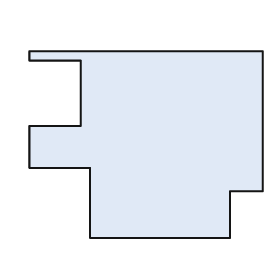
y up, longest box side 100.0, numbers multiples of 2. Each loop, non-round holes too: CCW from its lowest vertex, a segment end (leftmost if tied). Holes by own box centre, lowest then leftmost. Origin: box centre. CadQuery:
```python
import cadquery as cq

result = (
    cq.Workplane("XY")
    .moveTo(-24.0, -40.0)
    .lineTo(36.0, -40.0)
    .lineTo(36.0, -20.0)
    .lineTo(50.0, -20.0)
    .lineTo(50.0, 40.0)
    .lineTo(-50.0, 40.0)
    .lineTo(-50.0, 36.0)
    .lineTo(-28.0, 36.0)
    .lineTo(-28.0, 8.0)
    .lineTo(-50.0, 8.0)
    .lineTo(-50.0, -10.0)
    .lineTo(-24.0, -10.0)
    .close()
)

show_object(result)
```